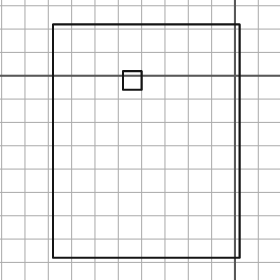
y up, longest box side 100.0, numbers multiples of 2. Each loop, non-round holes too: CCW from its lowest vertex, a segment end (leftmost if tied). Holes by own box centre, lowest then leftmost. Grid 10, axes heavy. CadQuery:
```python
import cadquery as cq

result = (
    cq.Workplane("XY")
    .moveTo(-78.0, -78.0)
    .lineTo(2.0, -78.0)
    .lineTo(2.0, 22.0)
    .lineTo(-78.0, 22.0)
    .close()
    .moveTo(-48.0, -6.0)
    .lineTo(-40.0, -6.0)
    .lineTo(-40.0, 2.0)
    .lineTo(-48.0, 2.0)
    .close()
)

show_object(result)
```